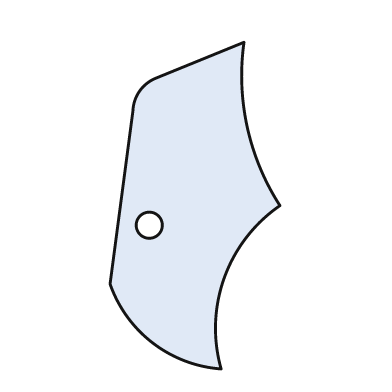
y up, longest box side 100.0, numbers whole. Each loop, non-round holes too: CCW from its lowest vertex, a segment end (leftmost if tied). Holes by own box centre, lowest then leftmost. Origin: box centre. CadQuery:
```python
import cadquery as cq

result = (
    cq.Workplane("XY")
    .moveTo(8.0, -50.0)
    .threePointArc((9.0, -22.0), (26.0, 0.0))
    .threePointArc((16.0, 24.0), (15.0, 50.0))
    .lineTo(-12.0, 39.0)
    .threePointArc((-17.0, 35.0), (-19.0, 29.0))
    .lineTo(-26.0, -24.0)
    .threePointArc((-13.0, -42.0), (8.0, -50.0))
    .close()
    .moveTo(-14.0, -6.0)
    .circle(4.0)
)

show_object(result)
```